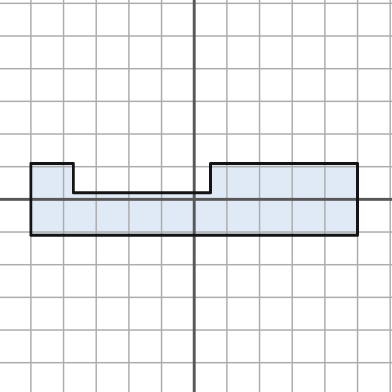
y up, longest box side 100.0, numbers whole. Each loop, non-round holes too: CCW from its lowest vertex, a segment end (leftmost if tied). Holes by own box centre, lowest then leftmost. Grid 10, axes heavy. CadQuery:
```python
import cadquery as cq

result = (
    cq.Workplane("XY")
    .moveTo(-50.0, -11.0)
    .lineTo(50.0, -11.0)
    .lineTo(50.0, 11.0)
    .lineTo(5.0, 11.0)
    .lineTo(5.0, 2.0)
    .lineTo(-37.0, 2.0)
    .lineTo(-37.0, 11.0)
    .lineTo(-50.0, 11.0)
    .close()
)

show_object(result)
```